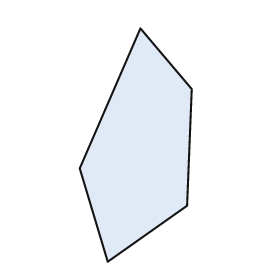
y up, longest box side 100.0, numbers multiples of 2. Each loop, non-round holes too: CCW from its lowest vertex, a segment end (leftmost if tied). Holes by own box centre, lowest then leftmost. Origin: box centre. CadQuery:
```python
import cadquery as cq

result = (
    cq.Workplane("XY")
    .moveTo(-12.0, -50.0)
    .lineTo(22.0, -26.0)
    .lineTo(24.0, 24.0)
    .lineTo(2.0, 50.0)
    .lineTo(-24.0, -10.0)
    .close()
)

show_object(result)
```